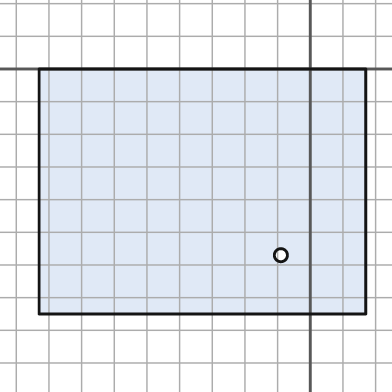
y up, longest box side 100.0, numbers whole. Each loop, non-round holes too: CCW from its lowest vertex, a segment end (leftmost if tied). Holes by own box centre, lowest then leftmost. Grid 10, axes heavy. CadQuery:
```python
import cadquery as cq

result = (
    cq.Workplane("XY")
    .moveTo(-83.0, -75.0)
    .lineTo(17.0, -75.0)
    .lineTo(17.0, 0.0)
    .lineTo(-83.0, 0.0)
    .close()
    .moveTo(-9.0, -57.0)
    .circle(2.0)
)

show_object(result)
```